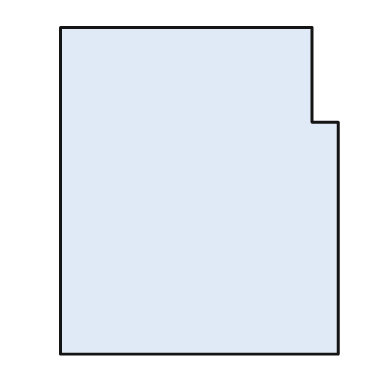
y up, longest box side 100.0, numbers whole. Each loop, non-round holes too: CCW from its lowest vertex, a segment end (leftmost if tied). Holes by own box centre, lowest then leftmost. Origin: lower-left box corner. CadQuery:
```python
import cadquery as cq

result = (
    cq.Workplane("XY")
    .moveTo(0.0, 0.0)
    .lineTo(85.0, 0.0)
    .lineTo(85.0, 71.0)
    .lineTo(77.0, 71.0)
    .lineTo(77.0, 100.0)
    .lineTo(0.0, 100.0)
    .close()
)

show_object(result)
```